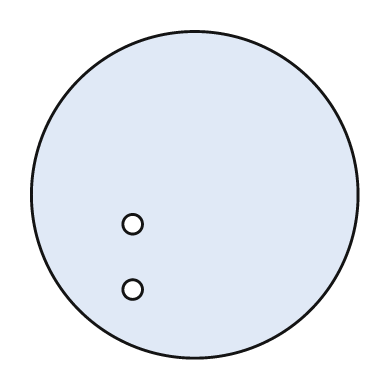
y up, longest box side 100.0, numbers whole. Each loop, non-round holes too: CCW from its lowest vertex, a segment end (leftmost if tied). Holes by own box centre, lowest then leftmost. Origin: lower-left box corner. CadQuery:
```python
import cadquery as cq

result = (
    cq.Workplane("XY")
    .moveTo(50.0, 50.0)
    .circle(50.0)
    .moveTo(31.0, 21.0)
    .circle(3.0)
    .moveTo(31.0, 41.0)
    .circle(3.0)
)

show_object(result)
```